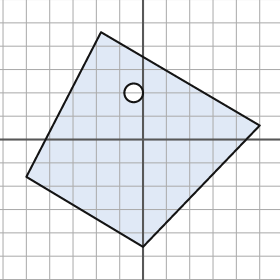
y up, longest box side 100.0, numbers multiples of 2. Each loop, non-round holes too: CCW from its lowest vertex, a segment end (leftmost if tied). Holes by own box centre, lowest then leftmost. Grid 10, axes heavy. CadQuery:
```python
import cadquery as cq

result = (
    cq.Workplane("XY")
    .moveTo(0.0, -46.0)
    .lineTo(50.0, 6.0)
    .lineTo(-18.0, 46.0)
    .lineTo(-50.0, -16.0)
    .close()
    .moveTo(-4.0, 20.0)
    .circle(4.0)
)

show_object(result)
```